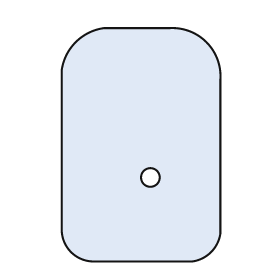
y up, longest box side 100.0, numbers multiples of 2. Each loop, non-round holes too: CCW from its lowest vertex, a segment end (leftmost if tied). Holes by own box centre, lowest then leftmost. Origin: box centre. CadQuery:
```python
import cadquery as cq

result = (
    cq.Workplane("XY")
    .moveTo(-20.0, -50.0)
    .lineTo(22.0, -50.0)
    .threePointArc((30.0, -46.0), (34.0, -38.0))
    .lineTo(34.0, 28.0)
    .threePointArc((28.0, 44.0), (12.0, 50.0))
    .lineTo(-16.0, 50.0)
    .threePointArc((-28.0, 44.0), (-34.0, 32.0))
    .lineTo(-34.0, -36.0)
    .threePointArc((-30.0, -46.0), (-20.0, -50.0))
    .close()
    .moveTo(4.0, -14.0)
    .circle(4.0)
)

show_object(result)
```